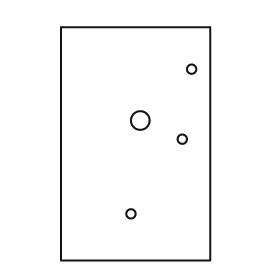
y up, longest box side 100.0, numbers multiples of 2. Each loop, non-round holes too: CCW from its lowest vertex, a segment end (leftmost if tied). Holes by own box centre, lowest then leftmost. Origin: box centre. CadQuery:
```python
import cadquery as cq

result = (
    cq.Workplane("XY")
    .moveTo(-32.0, -50.0)
    .lineTo(32.0, -50.0)
    .lineTo(32.0, 50.0)
    .lineTo(-32.0, 50.0)
    .close()
    .moveTo(-2.0, -30.0)
    .circle(2.0)
    .moveTo(20.0, 2.0)
    .circle(2.0)
    .moveTo(2.0, 10.0)
    .circle(4.0)
    .moveTo(24.0, 32.0)
    .circle(2.0)
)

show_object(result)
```